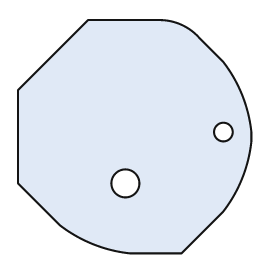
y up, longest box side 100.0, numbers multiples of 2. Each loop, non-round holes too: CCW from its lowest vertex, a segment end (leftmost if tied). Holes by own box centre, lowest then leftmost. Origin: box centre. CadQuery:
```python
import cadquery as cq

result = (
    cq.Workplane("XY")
    .moveTo(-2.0, -50.0)
    .lineTo(20.0, -50.0)
    .lineTo(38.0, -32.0)
    .threePointArc((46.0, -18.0), (50.0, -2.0))
    .lineTo(50.0, 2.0)
    .threePointArc((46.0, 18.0), (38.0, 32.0))
    .lineTo(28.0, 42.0)
    .threePointArc((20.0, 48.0), (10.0, 50.0))
    .lineTo(-20.0, 50.0)
    .lineTo(-50.0, 20.0)
    .lineTo(-50.0, -20.0)
    .lineTo(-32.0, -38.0)
    .threePointArc((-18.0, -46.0), (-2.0, -50.0))
    .close()
    .moveTo(-4.0, -20.0)
    .circle(6.0)
    .moveTo(38.0, 2.0)
    .circle(4.0)
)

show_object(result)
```